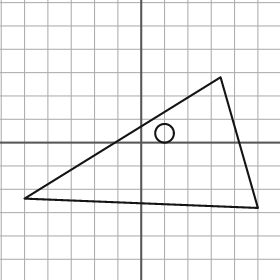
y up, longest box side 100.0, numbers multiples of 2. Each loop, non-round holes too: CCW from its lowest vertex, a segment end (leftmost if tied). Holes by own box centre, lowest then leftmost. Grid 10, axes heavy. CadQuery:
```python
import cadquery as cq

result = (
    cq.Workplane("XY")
    .moveTo(50.0, -28.0)
    .lineTo(34.0, 28.0)
    .lineTo(-50.0, -24.0)
    .close()
    .moveTo(10.0, 4.0)
    .circle(4.0)
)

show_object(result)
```